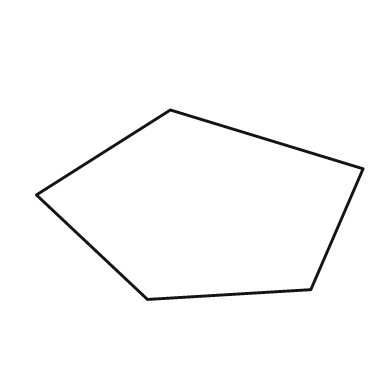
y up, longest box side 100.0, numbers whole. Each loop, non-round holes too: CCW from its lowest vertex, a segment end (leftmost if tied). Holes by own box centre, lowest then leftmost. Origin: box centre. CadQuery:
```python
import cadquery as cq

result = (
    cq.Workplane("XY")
    .moveTo(-16.0, -29.0)
    .lineTo(34.0, -26.0)
    .lineTo(50.0, 11.0)
    .lineTo(-9.0, 29.0)
    .lineTo(-50.0, 3.0)
    .close()
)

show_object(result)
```